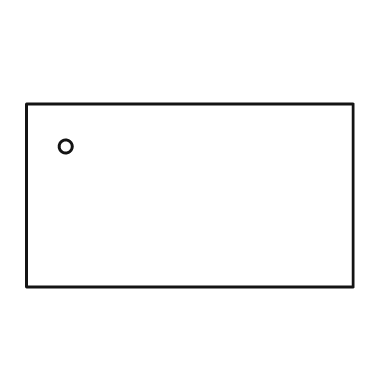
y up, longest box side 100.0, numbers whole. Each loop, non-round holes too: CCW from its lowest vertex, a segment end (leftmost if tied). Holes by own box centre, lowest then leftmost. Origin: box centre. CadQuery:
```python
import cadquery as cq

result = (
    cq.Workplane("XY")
    .moveTo(-50.0, -28.0)
    .lineTo(50.0, -28.0)
    .lineTo(50.0, 28.0)
    .lineTo(-50.0, 28.0)
    .close()
    .moveTo(-38.0, 15.0)
    .circle(2.0)
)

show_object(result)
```